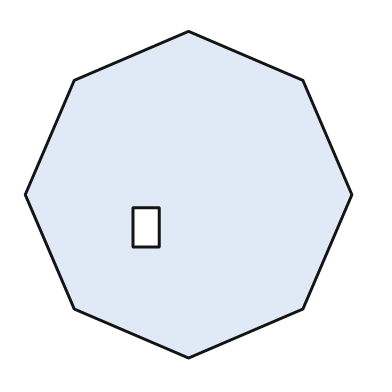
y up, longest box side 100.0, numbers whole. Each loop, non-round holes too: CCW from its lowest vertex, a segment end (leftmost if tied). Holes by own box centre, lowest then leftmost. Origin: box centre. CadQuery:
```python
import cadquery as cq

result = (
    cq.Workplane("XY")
    .moveTo(0.0, -50.0)
    .lineTo(35.0, -35.0)
    .lineTo(50.0, 0.0)
    .lineTo(35.0, 35.0)
    .lineTo(0.0, 50.0)
    .lineTo(-35.0, 35.0)
    .lineTo(-50.0, 0.0)
    .lineTo(-35.0, -35.0)
    .close()
    .moveTo(-17.0, -16.0)
    .lineTo(-9.0, -16.0)
    .lineTo(-9.0, -4.0)
    .lineTo(-17.0, -4.0)
    .close()
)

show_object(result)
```